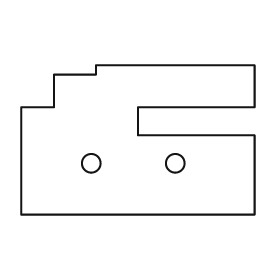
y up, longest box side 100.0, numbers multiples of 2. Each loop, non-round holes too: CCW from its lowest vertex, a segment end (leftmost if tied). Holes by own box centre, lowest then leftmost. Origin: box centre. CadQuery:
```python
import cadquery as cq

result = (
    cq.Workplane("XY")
    .moveTo(-50.0, -32.0)
    .lineTo(50.0, -32.0)
    .lineTo(50.0, 2.0)
    .lineTo(0.0, 2.0)
    .lineTo(0.0, 14.0)
    .lineTo(50.0, 14.0)
    .lineTo(50.0, 32.0)
    .lineTo(-18.0, 32.0)
    .lineTo(-18.0, 28.0)
    .lineTo(-36.0, 28.0)
    .lineTo(-36.0, 14.0)
    .lineTo(-50.0, 14.0)
    .close()
    .moveTo(-20.0, -10.0)
    .circle(4.0)
    .moveTo(16.0, -10.0)
    .circle(4.0)
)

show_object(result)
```